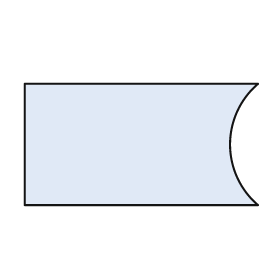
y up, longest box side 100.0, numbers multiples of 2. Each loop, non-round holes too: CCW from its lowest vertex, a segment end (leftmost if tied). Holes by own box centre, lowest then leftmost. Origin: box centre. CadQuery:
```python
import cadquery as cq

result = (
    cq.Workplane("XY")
    .moveTo(-50.0, -26.0)
    .lineTo(50.0, -26.0)
    .threePointArc((38.0, 0.0), (50.0, 26.0))
    .lineTo(-50.0, 26.0)
    .close()
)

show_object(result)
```